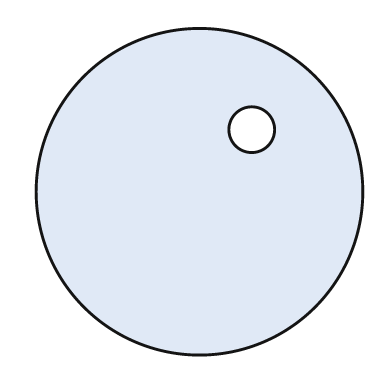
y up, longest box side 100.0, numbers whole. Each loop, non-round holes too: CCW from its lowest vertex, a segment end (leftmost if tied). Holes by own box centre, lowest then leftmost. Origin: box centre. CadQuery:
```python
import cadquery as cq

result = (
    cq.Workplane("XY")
    .moveTo(0.0, 0.0)
    .circle(50.0)
    .moveTo(16.0, 19.0)
    .circle(7.0)
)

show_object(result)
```